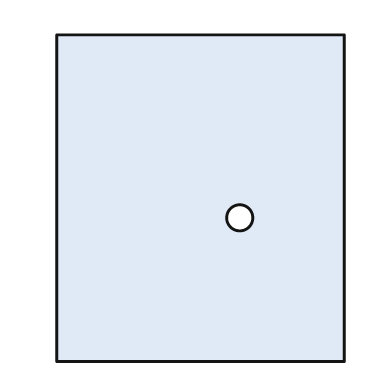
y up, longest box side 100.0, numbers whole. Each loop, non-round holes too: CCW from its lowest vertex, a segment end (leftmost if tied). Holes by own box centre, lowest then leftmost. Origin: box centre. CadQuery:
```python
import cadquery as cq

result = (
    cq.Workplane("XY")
    .moveTo(-44.0, -50.0)
    .lineTo(44.0, -50.0)
    .lineTo(44.0, 50.0)
    .lineTo(-44.0, 50.0)
    .close()
    .moveTo(12.0, -6.0)
    .circle(4.0)
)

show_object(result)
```